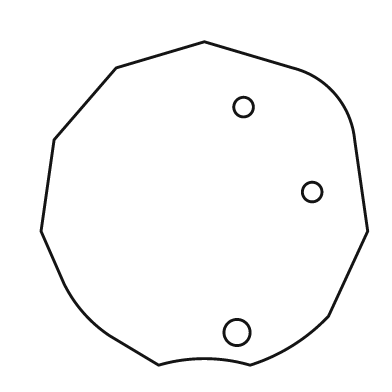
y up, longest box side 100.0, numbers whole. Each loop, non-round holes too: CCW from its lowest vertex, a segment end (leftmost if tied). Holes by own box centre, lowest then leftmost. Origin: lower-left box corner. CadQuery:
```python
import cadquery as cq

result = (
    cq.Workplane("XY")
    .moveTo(36.0, 0.0)
    .threePointArc((50.0, 2.0), (64.0, 0.0))
    .threePointArc((77.0, 6.0), (88.0, 15.0))
    .lineTo(100.0, 41.0)
    .lineTo(96.0, 69.0)
    .threePointArc((90.0, 83.0), (77.0, 91.0))
    .lineTo(50.0, 99.0)
    .lineTo(23.0, 91.0)
    .lineTo(4.0, 69.0)
    .lineTo(0.0, 41.0)
    .lineTo(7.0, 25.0)
    .threePointArc((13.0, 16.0), (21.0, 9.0))
    .close()
    .moveTo(60.0, 10.0)
    .circle(4.0)
    .moveTo(83.0, 53.0)
    .circle(3.0)
    .moveTo(62.0, 79.0)
    .circle(3.0)
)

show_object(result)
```